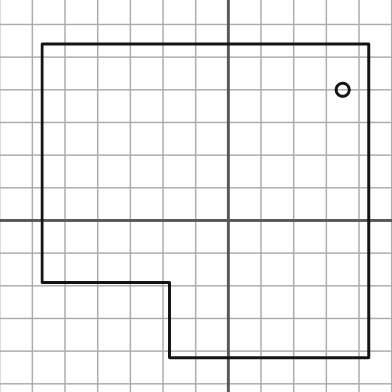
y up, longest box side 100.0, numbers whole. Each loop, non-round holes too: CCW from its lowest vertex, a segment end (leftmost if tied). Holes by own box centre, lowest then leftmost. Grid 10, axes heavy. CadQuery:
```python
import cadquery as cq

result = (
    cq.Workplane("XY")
    .moveTo(-18.0, -42.0)
    .lineTo(43.0, -42.0)
    .lineTo(43.0, 54.0)
    .lineTo(-57.0, 54.0)
    .lineTo(-57.0, -19.0)
    .lineTo(-18.0, -19.0)
    .close()
    .moveTo(35.0, 40.0)
    .circle(2.0)
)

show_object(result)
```